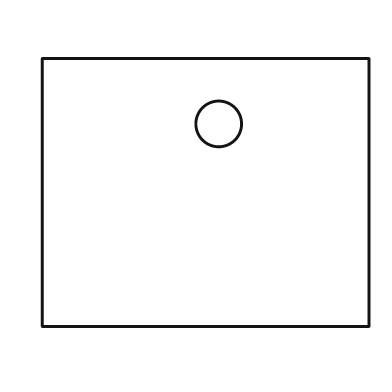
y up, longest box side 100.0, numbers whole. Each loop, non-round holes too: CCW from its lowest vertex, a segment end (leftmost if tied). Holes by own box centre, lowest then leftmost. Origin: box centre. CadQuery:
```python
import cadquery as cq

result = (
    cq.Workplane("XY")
    .moveTo(-50.0, -41.0)
    .lineTo(50.0, -41.0)
    .lineTo(50.0, 41.0)
    .lineTo(-50.0, 41.0)
    .close()
    .moveTo(4.0, 21.0)
    .circle(7.0)
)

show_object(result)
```